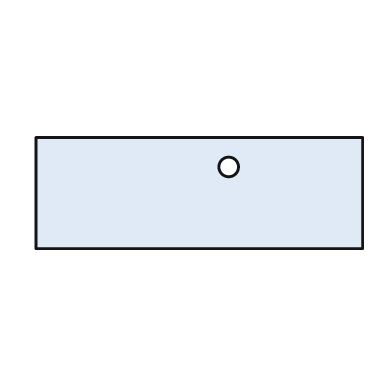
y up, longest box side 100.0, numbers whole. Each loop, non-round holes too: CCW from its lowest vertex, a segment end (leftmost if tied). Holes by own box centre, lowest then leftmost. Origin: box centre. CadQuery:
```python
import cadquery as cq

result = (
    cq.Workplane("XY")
    .moveTo(-50.0, -17.0)
    .lineTo(50.0, -17.0)
    .lineTo(50.0, 17.0)
    .lineTo(-50.0, 17.0)
    .close()
    .moveTo(9.0, 8.0)
    .circle(3.0)
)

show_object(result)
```